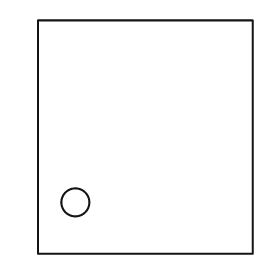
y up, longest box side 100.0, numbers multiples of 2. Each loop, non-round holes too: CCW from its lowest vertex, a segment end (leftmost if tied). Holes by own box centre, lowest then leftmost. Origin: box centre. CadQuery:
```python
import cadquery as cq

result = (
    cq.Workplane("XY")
    .moveTo(-46.0, -50.0)
    .lineTo(46.0, -50.0)
    .lineTo(46.0, 50.0)
    .lineTo(-46.0, 50.0)
    .close()
    .moveTo(-30.0, -28.0)
    .circle(6.0)
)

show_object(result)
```